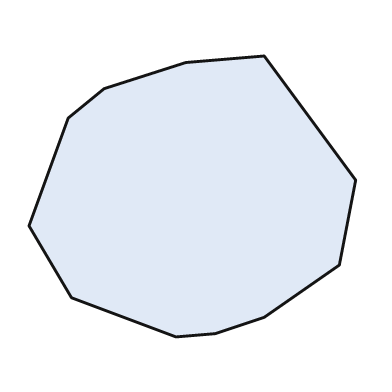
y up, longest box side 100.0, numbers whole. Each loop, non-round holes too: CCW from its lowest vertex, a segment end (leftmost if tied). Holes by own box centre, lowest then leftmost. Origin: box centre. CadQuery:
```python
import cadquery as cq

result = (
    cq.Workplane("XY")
    .moveTo(-5.0, -43.0)
    .lineTo(7.0, -42.0)
    .lineTo(22.0, -37.0)
    .lineTo(45.0, -21.0)
    .lineTo(50.0, 5.0)
    .lineTo(22.0, 43.0)
    .lineTo(-2.0, 41.0)
    .lineTo(-27.0, 33.0)
    .lineTo(-38.0, 24.0)
    .lineTo(-50.0, -9.0)
    .lineTo(-37.0, -31.0)
    .close()
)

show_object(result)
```